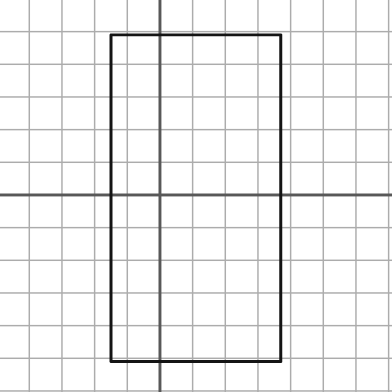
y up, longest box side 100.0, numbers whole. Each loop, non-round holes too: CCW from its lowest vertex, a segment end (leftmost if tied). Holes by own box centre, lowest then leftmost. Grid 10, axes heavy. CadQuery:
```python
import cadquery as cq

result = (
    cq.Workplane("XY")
    .moveTo(-15.0, -51.0)
    .lineTo(37.0, -51.0)
    .lineTo(37.0, 49.0)
    .lineTo(-15.0, 49.0)
    .close()
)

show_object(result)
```